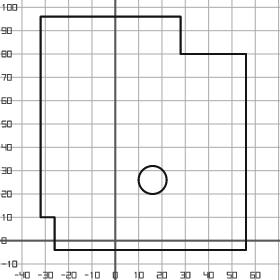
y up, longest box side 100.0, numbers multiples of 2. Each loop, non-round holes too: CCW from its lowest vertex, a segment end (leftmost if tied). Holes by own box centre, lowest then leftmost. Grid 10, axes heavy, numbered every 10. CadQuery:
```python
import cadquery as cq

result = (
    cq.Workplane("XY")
    .moveTo(-26.0, -4.0)
    .lineTo(56.0, -4.0)
    .lineTo(56.0, 80.0)
    .lineTo(28.0, 80.0)
    .lineTo(28.0, 96.0)
    .lineTo(-32.0, 96.0)
    .lineTo(-32.0, 10.0)
    .lineTo(-26.0, 10.0)
    .close()
    .moveTo(16.0, 26.0)
    .circle(6.0)
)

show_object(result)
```